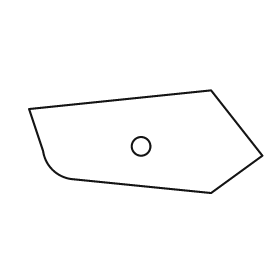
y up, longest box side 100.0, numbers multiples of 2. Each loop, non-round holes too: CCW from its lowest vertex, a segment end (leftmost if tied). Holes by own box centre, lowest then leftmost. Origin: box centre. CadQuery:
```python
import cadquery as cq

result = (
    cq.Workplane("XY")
    .moveTo(28.0, -22.0)
    .lineTo(50.0, -6.0)
    .lineTo(28.0, 22.0)
    .lineTo(-50.0, 14.0)
    .lineTo(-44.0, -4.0)
    .threePointArc((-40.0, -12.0), (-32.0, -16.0))
    .close()
    .moveTo(-2.0, -2.0)
    .circle(4.0)
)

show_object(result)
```